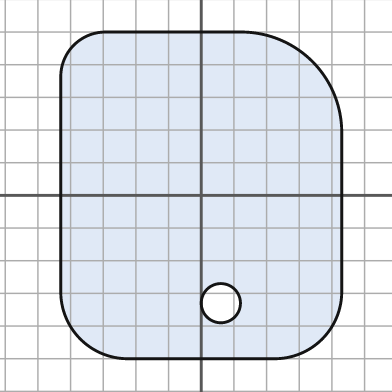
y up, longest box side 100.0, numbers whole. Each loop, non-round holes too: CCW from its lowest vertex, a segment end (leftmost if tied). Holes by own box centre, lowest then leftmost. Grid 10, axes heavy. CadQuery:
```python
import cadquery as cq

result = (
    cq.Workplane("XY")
    .moveTo(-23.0, -50.0)
    .lineTo(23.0, -50.0)
    .threePointArc((37.0, -44.0), (43.0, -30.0))
    .lineTo(43.0, 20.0)
    .threePointArc((34.0, 41.0), (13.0, 50.0))
    .lineTo(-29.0, 50.0)
    .threePointArc((-39.0, 46.0), (-43.0, 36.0))
    .lineTo(-43.0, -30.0)
    .threePointArc((-37.0, -44.0), (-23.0, -50.0))
    .close()
    .moveTo(6.0, -33.0)
    .circle(6.0)
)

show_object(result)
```